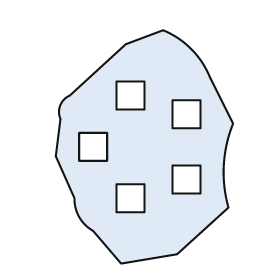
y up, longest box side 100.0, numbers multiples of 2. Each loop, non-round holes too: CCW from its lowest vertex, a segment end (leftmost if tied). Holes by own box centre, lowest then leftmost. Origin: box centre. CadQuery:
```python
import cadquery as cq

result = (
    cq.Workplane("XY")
    .moveTo(-10.0, -50.0)
    .lineTo(14.0, -46.0)
    .lineTo(36.0, -26.0)
    .threePointArc((34.0, -8.0), (38.0, 10.0))
    .lineTo(28.0, 30.0)
    .threePointArc((20.0, 42.0), (8.0, 50.0))
    .lineTo(-8.0, 44.0)
    .lineTo(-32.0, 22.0)
    .threePointArc((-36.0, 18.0), (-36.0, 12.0))
    .lineTo(-38.0, -4.0)
    .lineTo(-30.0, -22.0)
    .threePointArc((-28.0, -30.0), (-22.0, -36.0))
    .close()
    .moveTo(-12.0, -28.0)
    .lineTo(0.0, -28.0)
    .lineTo(0.0, -16.0)
    .lineTo(-12.0, -16.0)
    .close()
    .moveTo(12.0, -20.0)
    .lineTo(24.0, -20.0)
    .lineTo(24.0, -8.0)
    .lineTo(12.0, -8.0)
    .close()
    .moveTo(-28.0, -6.0)
    .lineTo(-16.0, -6.0)
    .lineTo(-16.0, 6.0)
    .lineTo(-28.0, 6.0)
    .close()
    .moveTo(12.0, 8.0)
    .lineTo(24.0, 8.0)
    .lineTo(24.0, 20.0)
    .lineTo(12.0, 20.0)
    .close()
    .moveTo(-12.0, 16.0)
    .lineTo(0.0, 16.0)
    .lineTo(0.0, 28.0)
    .lineTo(-12.0, 28.0)
    .close()
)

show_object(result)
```